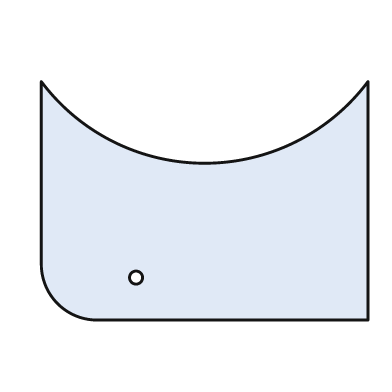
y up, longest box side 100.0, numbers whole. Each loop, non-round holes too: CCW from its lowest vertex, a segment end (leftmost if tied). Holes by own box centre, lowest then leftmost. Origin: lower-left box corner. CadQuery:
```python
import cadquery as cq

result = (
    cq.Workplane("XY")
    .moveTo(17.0, 0.0)
    .lineTo(100.0, 0.0)
    .lineTo(100.0, 73.0)
    .threePointArc((50.0, 48.0), (0.0, 73.0))
    .lineTo(0.0, 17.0)
    .threePointArc((5.0, 5.0), (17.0, 0.0))
    .close()
    .moveTo(29.0, 13.0)
    .circle(2.0)
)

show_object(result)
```